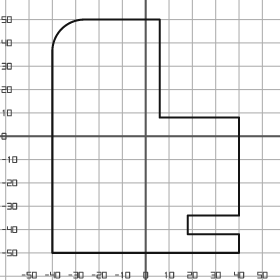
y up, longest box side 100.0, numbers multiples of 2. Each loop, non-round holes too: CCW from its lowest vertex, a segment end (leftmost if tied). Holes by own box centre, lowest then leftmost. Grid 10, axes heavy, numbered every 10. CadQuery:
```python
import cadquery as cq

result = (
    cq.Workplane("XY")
    .moveTo(-40.0, -50.0)
    .lineTo(40.0, -50.0)
    .lineTo(40.0, -42.0)
    .lineTo(18.0, -42.0)
    .lineTo(18.0, -34.0)
    .lineTo(40.0, -34.0)
    .lineTo(40.0, 8.0)
    .lineTo(6.0, 8.0)
    .lineTo(6.0, 50.0)
    .lineTo(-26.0, 50.0)
    .threePointArc((-36.0, 46.0), (-40.0, 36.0))
    .close()
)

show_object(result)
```